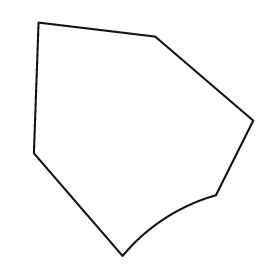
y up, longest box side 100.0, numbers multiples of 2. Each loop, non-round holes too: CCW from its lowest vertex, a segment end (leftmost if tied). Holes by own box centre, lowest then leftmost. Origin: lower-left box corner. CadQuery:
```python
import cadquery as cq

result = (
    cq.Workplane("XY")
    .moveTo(38.0, 0.0)
    .threePointArc((56.0, 16.0), (78.0, 26.0))
    .lineTo(94.0, 58.0)
    .lineTo(52.0, 94.0)
    .lineTo(2.0, 100.0)
    .lineTo(0.0, 44.0)
    .close()
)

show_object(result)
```